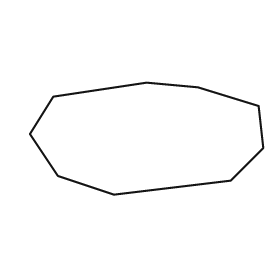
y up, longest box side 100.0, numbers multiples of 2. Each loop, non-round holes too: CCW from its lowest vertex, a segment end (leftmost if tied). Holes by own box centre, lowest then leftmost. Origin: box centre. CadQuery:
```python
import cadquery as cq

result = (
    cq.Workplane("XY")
    .moveTo(-14.0, -24.0)
    .lineTo(36.0, -18.0)
    .lineTo(50.0, -4.0)
    .lineTo(48.0, 14.0)
    .lineTo(22.0, 22.0)
    .lineTo(0.0, 24.0)
    .lineTo(-40.0, 18.0)
    .lineTo(-50.0, 2.0)
    .lineTo(-38.0, -16.0)
    .close()
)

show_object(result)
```